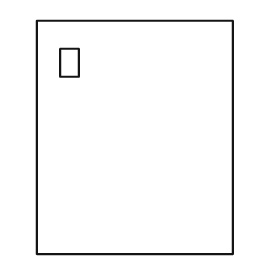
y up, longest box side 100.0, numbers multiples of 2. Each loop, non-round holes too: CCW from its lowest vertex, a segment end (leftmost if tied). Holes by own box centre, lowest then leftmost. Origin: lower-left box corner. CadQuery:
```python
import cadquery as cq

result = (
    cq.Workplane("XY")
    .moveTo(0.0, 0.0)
    .lineTo(84.0, 0.0)
    .lineTo(84.0, 100.0)
    .lineTo(0.0, 100.0)
    .close()
    .moveTo(10.0, 76.0)
    .lineTo(18.0, 76.0)
    .lineTo(18.0, 88.0)
    .lineTo(10.0, 88.0)
    .close()
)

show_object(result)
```